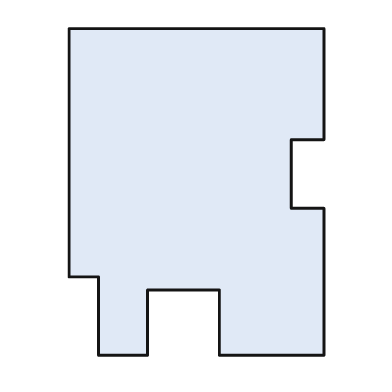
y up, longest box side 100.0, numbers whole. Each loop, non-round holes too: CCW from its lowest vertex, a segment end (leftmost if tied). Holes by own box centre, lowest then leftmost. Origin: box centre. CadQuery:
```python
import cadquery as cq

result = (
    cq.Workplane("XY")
    .moveTo(-30.0, -50.0)
    .lineTo(-15.0, -50.0)
    .lineTo(-15.0, -30.0)
    .lineTo(7.0, -30.0)
    .lineTo(7.0, -50.0)
    .lineTo(39.0, -50.0)
    .lineTo(39.0, -5.0)
    .lineTo(29.0, -5.0)
    .lineTo(29.0, 16.0)
    .lineTo(39.0, 16.0)
    .lineTo(39.0, 50.0)
    .lineTo(-39.0, 50.0)
    .lineTo(-39.0, -26.0)
    .lineTo(-30.0, -26.0)
    .close()
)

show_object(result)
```